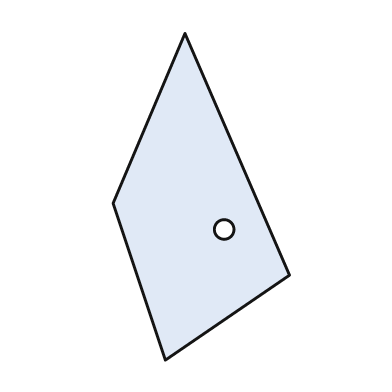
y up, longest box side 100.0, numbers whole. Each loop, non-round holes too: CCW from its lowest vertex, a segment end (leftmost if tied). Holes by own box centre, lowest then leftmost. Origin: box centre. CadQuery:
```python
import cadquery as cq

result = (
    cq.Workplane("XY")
    .moveTo(-11.0, -50.0)
    .lineTo(27.0, -24.0)
    .lineTo(-5.0, 50.0)
    .lineTo(-27.0, -2.0)
    .close()
    .moveTo(7.0, -10.0)
    .circle(3.0)
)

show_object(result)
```